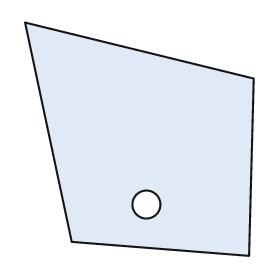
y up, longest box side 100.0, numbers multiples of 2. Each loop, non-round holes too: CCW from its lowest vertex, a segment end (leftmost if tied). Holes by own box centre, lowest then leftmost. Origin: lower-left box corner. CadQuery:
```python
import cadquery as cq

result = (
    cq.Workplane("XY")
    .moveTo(96.0, 0.0)
    .lineTo(98.0, 76.0)
    .lineTo(0.0, 100.0)
    .lineTo(20.0, 6.0)
    .close()
    .moveTo(52.0, 22.0)
    .circle(6.0)
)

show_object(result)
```